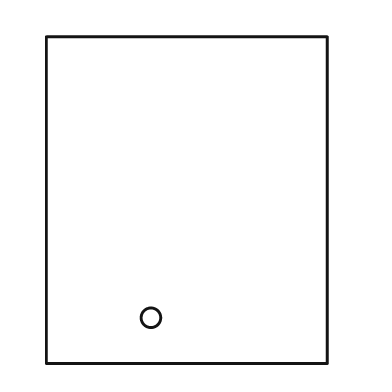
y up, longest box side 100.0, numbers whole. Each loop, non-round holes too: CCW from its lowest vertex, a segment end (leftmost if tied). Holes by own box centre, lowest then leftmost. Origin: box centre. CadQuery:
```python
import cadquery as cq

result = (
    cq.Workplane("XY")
    .moveTo(-43.0, -50.0)
    .lineTo(43.0, -50.0)
    .lineTo(43.0, 50.0)
    .lineTo(-43.0, 50.0)
    .close()
    .moveTo(-11.0, -36.0)
    .circle(3.0)
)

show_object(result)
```